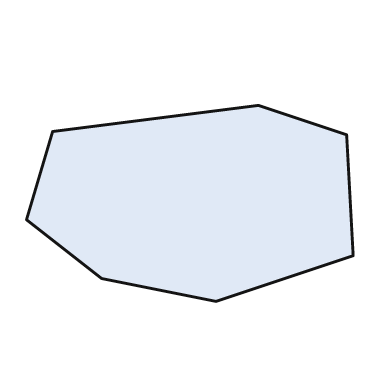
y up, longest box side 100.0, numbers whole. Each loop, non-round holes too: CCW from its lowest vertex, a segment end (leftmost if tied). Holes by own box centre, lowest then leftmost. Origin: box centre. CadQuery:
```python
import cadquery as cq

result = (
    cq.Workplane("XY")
    .moveTo(8.0, -30.0)
    .lineTo(50.0, -16.0)
    .lineTo(48.0, 21.0)
    .lineTo(21.0, 30.0)
    .lineTo(-42.0, 22.0)
    .lineTo(-50.0, -5.0)
    .lineTo(-27.0, -23.0)
    .close()
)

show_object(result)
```